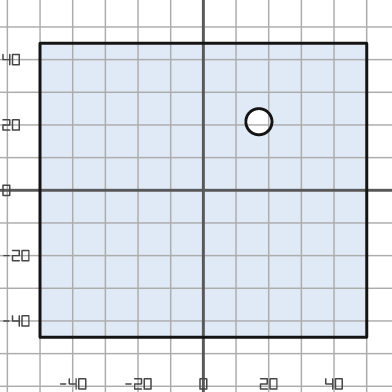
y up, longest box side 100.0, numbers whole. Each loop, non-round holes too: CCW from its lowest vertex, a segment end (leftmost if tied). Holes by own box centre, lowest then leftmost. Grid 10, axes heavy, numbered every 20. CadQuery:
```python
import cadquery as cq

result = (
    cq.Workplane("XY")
    .moveTo(-50.0, -45.0)
    .lineTo(50.0, -45.0)
    .lineTo(50.0, 45.0)
    .lineTo(-50.0, 45.0)
    .close()
    .moveTo(17.0, 21.0)
    .circle(4.0)
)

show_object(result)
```